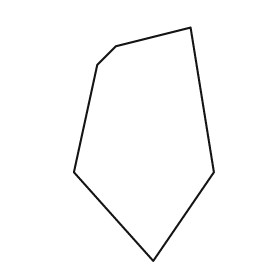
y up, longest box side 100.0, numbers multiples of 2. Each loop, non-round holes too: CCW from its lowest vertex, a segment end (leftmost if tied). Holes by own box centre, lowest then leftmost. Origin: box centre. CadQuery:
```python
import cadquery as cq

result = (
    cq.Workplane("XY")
    .moveTo(4.0, -50.0)
    .lineTo(30.0, -12.0)
    .lineTo(20.0, 50.0)
    .lineTo(-12.0, 42.0)
    .lineTo(-20.0, 34.0)
    .lineTo(-30.0, -12.0)
    .close()
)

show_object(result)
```